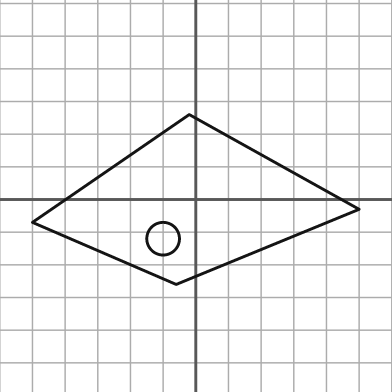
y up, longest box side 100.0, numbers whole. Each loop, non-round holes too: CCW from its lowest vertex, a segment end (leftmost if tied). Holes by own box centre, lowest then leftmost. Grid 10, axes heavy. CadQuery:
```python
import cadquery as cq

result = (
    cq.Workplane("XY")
    .moveTo(-6.0, -26.0)
    .lineTo(50.0, -3.0)
    .lineTo(-2.0, 26.0)
    .lineTo(-50.0, -7.0)
    .close()
    .moveTo(-10.0, -12.0)
    .circle(5.0)
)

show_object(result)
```